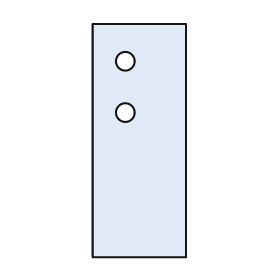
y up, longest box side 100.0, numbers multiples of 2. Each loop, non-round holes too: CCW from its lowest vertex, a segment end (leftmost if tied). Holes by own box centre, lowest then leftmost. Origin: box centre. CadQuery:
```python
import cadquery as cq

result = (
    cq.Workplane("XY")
    .moveTo(-20.0, -50.0)
    .lineTo(20.0, -50.0)
    .lineTo(20.0, 50.0)
    .lineTo(-20.0, 50.0)
    .close()
    .moveTo(-6.0, 12.0)
    .circle(4.0)
    .moveTo(-6.0, 34.0)
    .circle(4.0)
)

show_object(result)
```